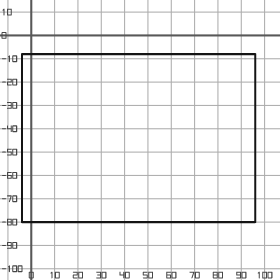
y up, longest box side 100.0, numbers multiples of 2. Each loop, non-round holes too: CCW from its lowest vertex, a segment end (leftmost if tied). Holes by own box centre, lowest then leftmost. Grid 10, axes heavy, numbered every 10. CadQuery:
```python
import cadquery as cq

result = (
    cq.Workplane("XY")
    .moveTo(-4.0, -80.0)
    .lineTo(96.0, -80.0)
    .lineTo(96.0, -8.0)
    .lineTo(-4.0, -8.0)
    .close()
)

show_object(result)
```